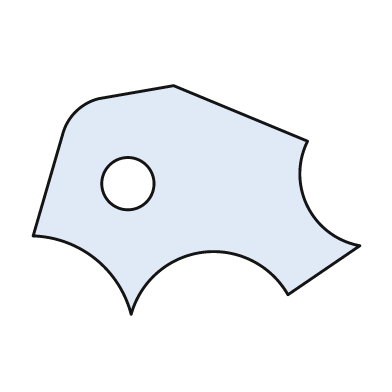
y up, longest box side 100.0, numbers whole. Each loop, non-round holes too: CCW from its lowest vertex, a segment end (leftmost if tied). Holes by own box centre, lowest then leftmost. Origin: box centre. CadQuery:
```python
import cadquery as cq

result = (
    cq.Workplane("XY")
    .moveTo(-20.0, -35.0)
    .threePointArc((2.0, -16.0), (28.0, -29.0))
    .lineTo(50.0, -14.0)
    .threePointArc((34.0, -2.0), (34.0, 18.0))
    .lineTo(-7.0, 35.0)
    .lineTo(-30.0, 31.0)
    .threePointArc((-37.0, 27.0), (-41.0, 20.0))
    .lineTo(-50.0, -11.0)
    .threePointArc((-31.0, -18.0), (-20.0, -35.0))
    .close()
    .moveTo(-21.0, 5.0)
    .circle(8.0)
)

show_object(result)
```